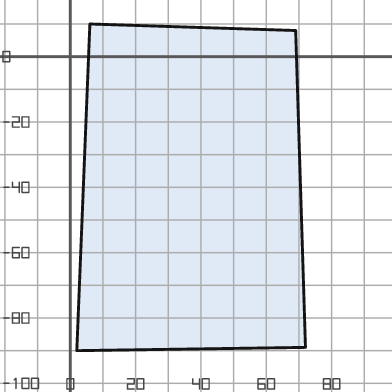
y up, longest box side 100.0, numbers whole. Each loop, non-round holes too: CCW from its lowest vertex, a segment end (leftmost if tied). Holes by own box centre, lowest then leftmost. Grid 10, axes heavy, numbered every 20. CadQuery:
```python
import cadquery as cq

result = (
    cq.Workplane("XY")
    .moveTo(2.0, -90.0)
    .lineTo(72.0, -89.0)
    .lineTo(69.0, 8.0)
    .lineTo(6.0, 10.0)
    .close()
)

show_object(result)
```